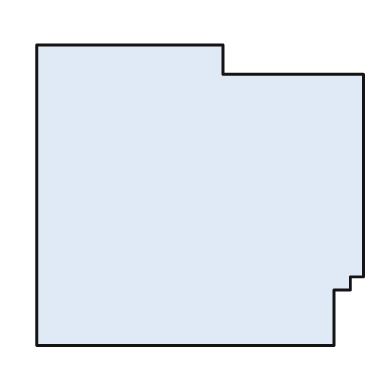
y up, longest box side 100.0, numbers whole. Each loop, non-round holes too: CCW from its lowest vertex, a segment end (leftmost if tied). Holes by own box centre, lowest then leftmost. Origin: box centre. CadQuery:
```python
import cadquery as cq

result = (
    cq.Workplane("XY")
    .moveTo(-50.0, -46.0)
    .lineTo(41.0, -46.0)
    .lineTo(41.0, -29.0)
    .lineTo(46.0, -29.0)
    .lineTo(46.0, -25.0)
    .lineTo(50.0, -25.0)
    .lineTo(50.0, 37.0)
    .lineTo(7.0, 37.0)
    .lineTo(7.0, 46.0)
    .lineTo(-50.0, 46.0)
    .close()
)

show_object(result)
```